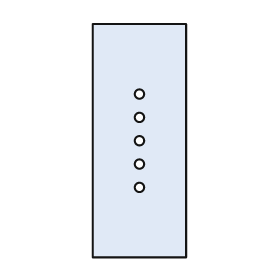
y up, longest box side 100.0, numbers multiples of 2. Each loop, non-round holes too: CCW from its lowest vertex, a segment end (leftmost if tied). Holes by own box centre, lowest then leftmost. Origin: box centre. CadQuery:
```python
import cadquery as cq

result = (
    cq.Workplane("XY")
    .moveTo(-20.0, -50.0)
    .lineTo(20.0, -50.0)
    .lineTo(20.0, 50.0)
    .lineTo(-20.0, 50.0)
    .close()
    .moveTo(0.0, -20.0)
    .circle(2.0)
    .moveTo(0.0, -10.0)
    .circle(2.0)
    .moveTo(0.0, 0.0)
    .circle(2.0)
    .moveTo(0.0, 10.0)
    .circle(2.0)
    .moveTo(0.0, 20.0)
    .circle(2.0)
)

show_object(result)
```